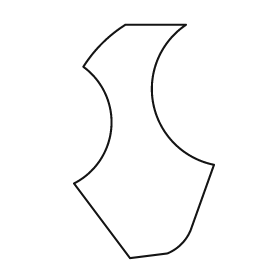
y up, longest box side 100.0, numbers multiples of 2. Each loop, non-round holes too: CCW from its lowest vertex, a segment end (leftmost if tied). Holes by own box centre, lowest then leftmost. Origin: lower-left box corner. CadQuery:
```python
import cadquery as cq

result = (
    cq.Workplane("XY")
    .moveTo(24.0, 0.0)
    .lineTo(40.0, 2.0)
    .threePointArc((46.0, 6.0), (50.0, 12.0))
    .lineTo(60.0, 40.0)
    .threePointArc((34.0, 66.0), (48.0, 100.0))
    .lineTo(22.0, 100.0)
    .threePointArc((12.0, 92.0), (4.0, 82.0))
    .threePointArc((16.0, 56.0), (0.0, 32.0))
    .close()
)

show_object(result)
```